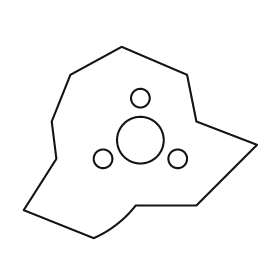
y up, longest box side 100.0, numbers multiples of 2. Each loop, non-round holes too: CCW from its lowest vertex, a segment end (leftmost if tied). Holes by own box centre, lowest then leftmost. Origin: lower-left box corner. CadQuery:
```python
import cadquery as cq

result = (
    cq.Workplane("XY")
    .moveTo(30.0, 0.0)
    .threePointArc((40.0, 6.0), (48.0, 14.0))
    .lineTo(74.0, 14.0)
    .lineTo(100.0, 40.0)
    .lineTo(74.0, 50.0)
    .lineTo(70.0, 70.0)
    .lineTo(42.0, 82.0)
    .lineTo(20.0, 70.0)
    .lineTo(12.0, 50.0)
    .lineTo(14.0, 34.0)
    .lineTo(0.0, 12.0)
    .close()
    .moveTo(34.0, 34.0)
    .circle(4.0)
    .moveTo(66.0, 34.0)
    .circle(4.0)
    .moveTo(50.0, 42.0)
    .circle(10.0)
    .moveTo(50.0, 60.0)
    .circle(4.0)
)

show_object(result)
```